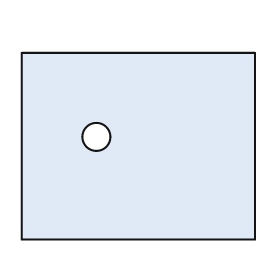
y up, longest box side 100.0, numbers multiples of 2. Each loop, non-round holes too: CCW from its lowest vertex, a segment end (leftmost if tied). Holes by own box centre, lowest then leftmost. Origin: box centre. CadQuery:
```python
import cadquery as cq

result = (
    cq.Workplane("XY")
    .moveTo(-50.0, -40.0)
    .lineTo(50.0, -40.0)
    .lineTo(50.0, 40.0)
    .lineTo(-50.0, 40.0)
    .close()
    .moveTo(-18.0, 4.0)
    .circle(6.0)
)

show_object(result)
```